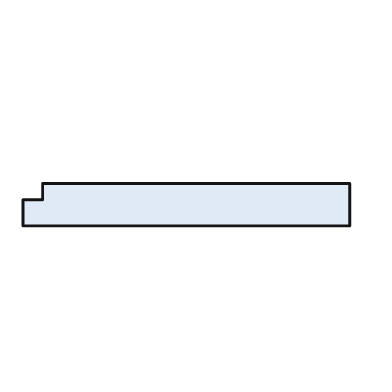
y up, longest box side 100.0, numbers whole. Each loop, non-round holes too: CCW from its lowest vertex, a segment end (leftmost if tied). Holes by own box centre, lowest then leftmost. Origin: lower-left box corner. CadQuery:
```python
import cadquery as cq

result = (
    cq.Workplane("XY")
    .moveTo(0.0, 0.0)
    .lineTo(100.0, 0.0)
    .lineTo(100.0, 13.0)
    .lineTo(6.0, 13.0)
    .lineTo(6.0, 8.0)
    .lineTo(0.0, 8.0)
    .close()
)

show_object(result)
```